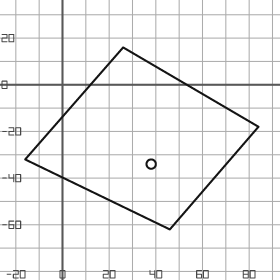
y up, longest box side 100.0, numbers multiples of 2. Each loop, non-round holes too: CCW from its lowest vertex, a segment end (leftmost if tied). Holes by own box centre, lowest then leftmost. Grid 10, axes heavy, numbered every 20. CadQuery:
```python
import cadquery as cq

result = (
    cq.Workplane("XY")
    .moveTo(46.0, -62.0)
    .lineTo(84.0, -18.0)
    .lineTo(26.0, 16.0)
    .lineTo(-16.0, -32.0)
    .close()
    .moveTo(38.0, -34.0)
    .circle(2.0)
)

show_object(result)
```